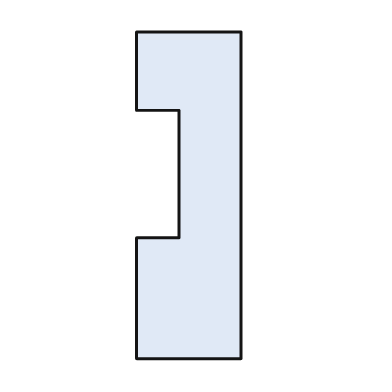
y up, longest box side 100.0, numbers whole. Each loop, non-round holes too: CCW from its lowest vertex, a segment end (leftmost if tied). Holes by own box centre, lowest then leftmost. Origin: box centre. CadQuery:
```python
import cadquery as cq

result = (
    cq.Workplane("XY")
    .moveTo(-16.0, -50.0)
    .lineTo(16.0, -50.0)
    .lineTo(16.0, 50.0)
    .lineTo(-16.0, 50.0)
    .lineTo(-16.0, 26.0)
    .lineTo(-3.0, 26.0)
    .lineTo(-3.0, -13.0)
    .lineTo(-16.0, -13.0)
    .close()
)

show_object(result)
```